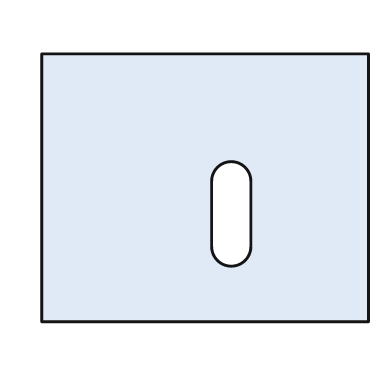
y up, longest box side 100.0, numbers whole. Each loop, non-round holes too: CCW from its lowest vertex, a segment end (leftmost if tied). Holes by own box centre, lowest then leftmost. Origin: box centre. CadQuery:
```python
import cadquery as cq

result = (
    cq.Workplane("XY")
    .moveTo(-50.0, -41.0)
    .lineTo(50.0, -41.0)
    .lineTo(50.0, 41.0)
    .lineTo(-50.0, 41.0)
    .close()
    .moveTo(2.0, -18.0)
    .threePointArc((8.0, -24.0), (14.0, -18.0))
    .lineTo(14.0, 2.0)
    .threePointArc((8.0, 8.0), (2.0, 2.0))
    .close()
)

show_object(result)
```